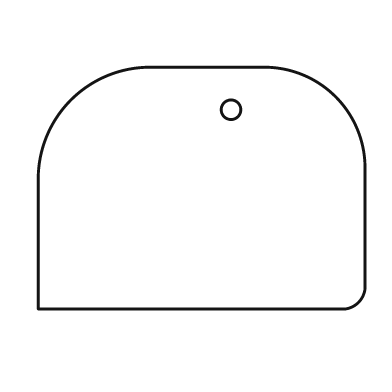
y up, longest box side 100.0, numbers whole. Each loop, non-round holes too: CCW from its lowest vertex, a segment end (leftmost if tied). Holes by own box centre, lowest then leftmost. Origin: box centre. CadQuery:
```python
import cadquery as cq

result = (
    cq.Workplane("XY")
    .moveTo(-50.0, -37.0)
    .lineTo(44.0, -37.0)
    .threePointArc((48.0, -35.0), (50.0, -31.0))
    .lineTo(50.0, 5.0)
    .threePointArc((41.0, 28.0), (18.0, 37.0))
    .lineTo(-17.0, 37.0)
    .threePointArc((-40.0, 27.0), (-50.0, 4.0))
    .close()
    .moveTo(9.0, 24.0)
    .circle(3.0)
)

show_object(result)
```